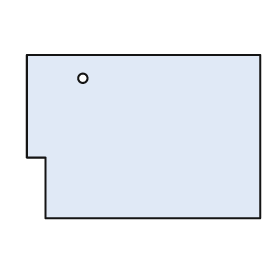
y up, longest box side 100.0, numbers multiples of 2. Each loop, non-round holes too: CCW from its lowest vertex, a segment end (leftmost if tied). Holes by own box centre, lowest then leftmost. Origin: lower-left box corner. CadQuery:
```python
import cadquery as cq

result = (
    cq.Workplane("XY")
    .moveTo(8.0, 0.0)
    .lineTo(100.0, 0.0)
    .lineTo(100.0, 70.0)
    .lineTo(0.0, 70.0)
    .lineTo(0.0, 26.0)
    .lineTo(8.0, 26.0)
    .close()
    .moveTo(24.0, 60.0)
    .circle(2.0)
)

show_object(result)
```